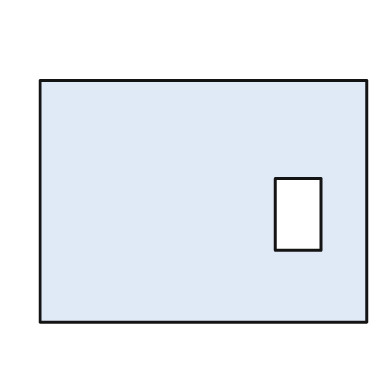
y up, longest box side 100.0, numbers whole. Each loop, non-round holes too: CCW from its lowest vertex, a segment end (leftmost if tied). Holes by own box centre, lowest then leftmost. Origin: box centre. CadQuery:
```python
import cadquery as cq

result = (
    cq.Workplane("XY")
    .moveTo(-50.0, -37.0)
    .lineTo(50.0, -37.0)
    .lineTo(50.0, 37.0)
    .lineTo(-50.0, 37.0)
    .close()
    .moveTo(22.0, -15.0)
    .lineTo(36.0, -15.0)
    .lineTo(36.0, 7.0)
    .lineTo(22.0, 7.0)
    .close()
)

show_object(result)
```